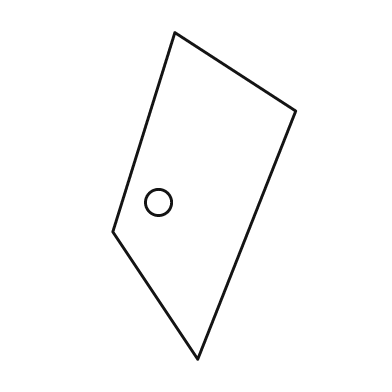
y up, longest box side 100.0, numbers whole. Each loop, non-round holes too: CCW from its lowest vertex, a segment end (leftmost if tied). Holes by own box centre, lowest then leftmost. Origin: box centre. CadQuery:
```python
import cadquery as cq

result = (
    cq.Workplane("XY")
    .moveTo(-2.0, -50.0)
    .lineTo(28.0, 26.0)
    .lineTo(-9.0, 50.0)
    .lineTo(-28.0, -11.0)
    .close()
    .moveTo(-14.0, -2.0)
    .circle(4.0)
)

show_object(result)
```